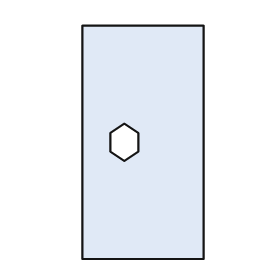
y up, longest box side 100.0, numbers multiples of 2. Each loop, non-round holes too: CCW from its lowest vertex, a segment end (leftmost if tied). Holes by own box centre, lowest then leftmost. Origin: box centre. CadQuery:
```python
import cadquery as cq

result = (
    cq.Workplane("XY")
    .moveTo(-26.0, -50.0)
    .lineTo(26.0, -50.0)
    .lineTo(26.0, 50.0)
    .lineTo(-26.0, 50.0)
    .close()
    .moveTo(-8.0, -8.0)
    .lineTo(-2.0, -4.0)
    .lineTo(-2.0, 4.0)
    .lineTo(-8.0, 8.0)
    .lineTo(-14.0, 4.0)
    .lineTo(-14.0, -4.0)
    .close()
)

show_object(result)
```